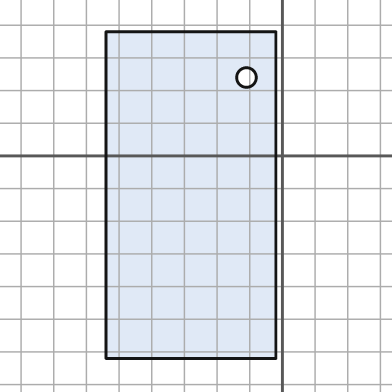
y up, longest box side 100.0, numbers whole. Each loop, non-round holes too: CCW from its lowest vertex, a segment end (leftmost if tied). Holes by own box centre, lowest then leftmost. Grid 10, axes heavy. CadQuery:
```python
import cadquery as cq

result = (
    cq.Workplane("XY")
    .moveTo(-54.0, -62.0)
    .lineTo(-2.0, -62.0)
    .lineTo(-2.0, 38.0)
    .lineTo(-54.0, 38.0)
    .close()
    .moveTo(-11.0, 24.0)
    .circle(3.0)
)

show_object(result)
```